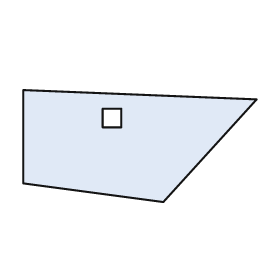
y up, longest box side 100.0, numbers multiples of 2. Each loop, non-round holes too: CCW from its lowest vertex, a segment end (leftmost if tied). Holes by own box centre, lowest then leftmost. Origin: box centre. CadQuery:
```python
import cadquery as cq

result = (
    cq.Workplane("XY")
    .moveTo(10.0, -24.0)
    .lineTo(50.0, 20.0)
    .lineTo(-50.0, 24.0)
    .lineTo(-50.0, -16.0)
    .close()
    .moveTo(-16.0, 8.0)
    .lineTo(-8.0, 8.0)
    .lineTo(-8.0, 16.0)
    .lineTo(-16.0, 16.0)
    .close()
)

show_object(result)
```